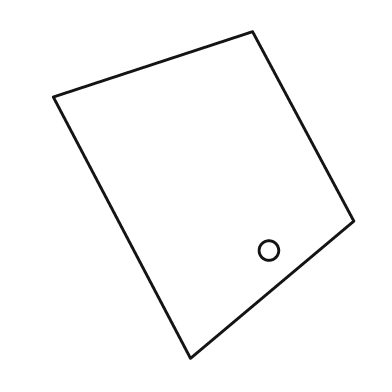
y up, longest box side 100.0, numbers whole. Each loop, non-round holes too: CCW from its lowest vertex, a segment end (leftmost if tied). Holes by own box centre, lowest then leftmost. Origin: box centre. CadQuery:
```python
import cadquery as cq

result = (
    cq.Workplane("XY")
    .moveTo(-4.0, -50.0)
    .lineTo(46.0, -8.0)
    .lineTo(15.0, 50.0)
    .lineTo(-46.0, 30.0)
    .close()
    .moveTo(20.0, -17.0)
    .circle(3.0)
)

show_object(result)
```